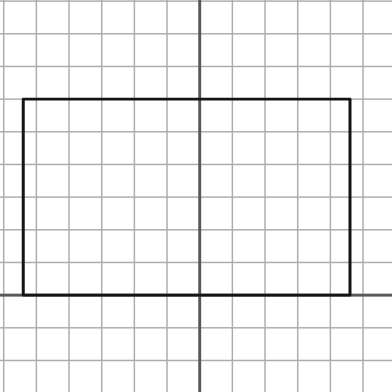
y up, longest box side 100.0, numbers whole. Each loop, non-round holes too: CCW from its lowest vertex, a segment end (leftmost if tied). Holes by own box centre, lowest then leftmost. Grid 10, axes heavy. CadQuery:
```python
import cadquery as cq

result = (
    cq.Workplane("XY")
    .moveTo(-54.0, 0.0)
    .lineTo(46.0, 0.0)
    .lineTo(46.0, 60.0)
    .lineTo(-54.0, 60.0)
    .close()
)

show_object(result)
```